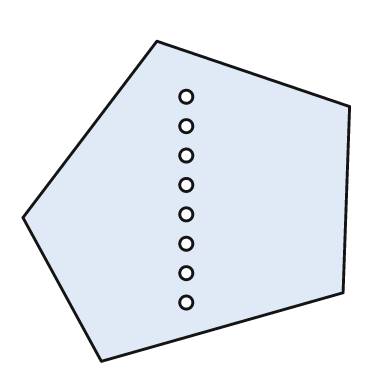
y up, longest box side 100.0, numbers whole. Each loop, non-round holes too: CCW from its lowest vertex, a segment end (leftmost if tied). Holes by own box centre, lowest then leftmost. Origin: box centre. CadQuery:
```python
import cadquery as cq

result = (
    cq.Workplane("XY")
    .moveTo(-26.0, -49.0)
    .lineTo(48.0, -28.0)
    .lineTo(50.0, 29.0)
    .lineTo(-9.0, 49.0)
    .lineTo(-50.0, -5.0)
    .close()
    .moveTo(0.0, -31.0)
    .circle(2.0)
    .moveTo(0.0, -22.0)
    .circle(2.0)
    .moveTo(0.0, -13.0)
    .circle(2.0)
    .moveTo(0.0, -4.0)
    .circle(2.0)
    .moveTo(0.0, 5.0)
    .circle(2.0)
    .moveTo(0.0, 14.0)
    .circle(2.0)
    .moveTo(0.0, 23.0)
    .circle(2.0)
    .moveTo(0.0, 32.0)
    .circle(2.0)
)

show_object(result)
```